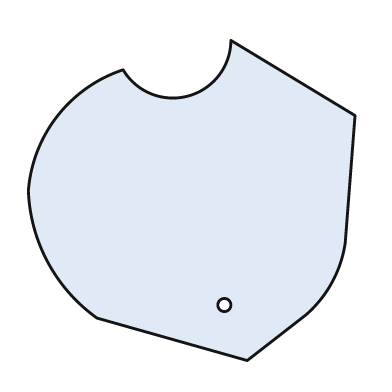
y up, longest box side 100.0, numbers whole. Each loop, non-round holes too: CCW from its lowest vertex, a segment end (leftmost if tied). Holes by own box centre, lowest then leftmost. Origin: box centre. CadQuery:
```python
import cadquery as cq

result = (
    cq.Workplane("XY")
    .moveTo(17.0, -49.0)
    .lineTo(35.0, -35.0)
    .threePointArc((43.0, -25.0), (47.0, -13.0))
    .lineTo(50.0, 26.0)
    .lineTo(12.0, 49.0)
    .threePointArc((-1.0, 32.0), (-21.0, 40.0))
    .threePointArc((-41.0, 26.0), (-50.0, 3.0))
    .threePointArc((-44.0, -19.0), (-29.0, -36.0))
    .close()
    .moveTo(10.0, -32.0)
    .circle(2.0)
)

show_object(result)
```